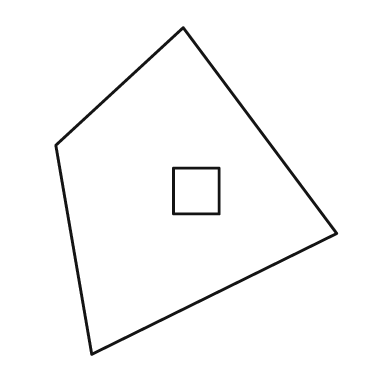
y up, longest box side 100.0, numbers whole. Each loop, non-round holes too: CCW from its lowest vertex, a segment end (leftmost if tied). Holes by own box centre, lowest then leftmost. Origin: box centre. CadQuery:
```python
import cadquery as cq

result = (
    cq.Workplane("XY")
    .moveTo(-32.0, -50.0)
    .lineTo(43.0, -13.0)
    .lineTo(-4.0, 50.0)
    .lineTo(-43.0, 14.0)
    .close()
    .moveTo(-7.0, -7.0)
    .lineTo(7.0, -7.0)
    .lineTo(7.0, 7.0)
    .lineTo(-7.0, 7.0)
    .close()
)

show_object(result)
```